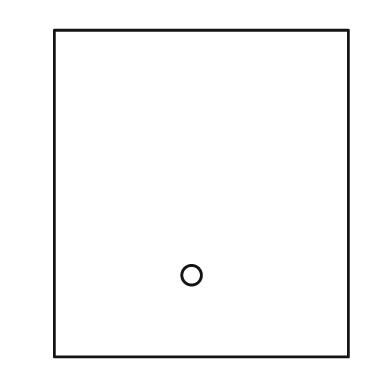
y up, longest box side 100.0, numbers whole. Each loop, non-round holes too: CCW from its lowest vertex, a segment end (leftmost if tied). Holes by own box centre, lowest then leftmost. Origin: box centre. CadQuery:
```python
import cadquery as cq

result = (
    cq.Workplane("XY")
    .moveTo(-45.0, -50.0)
    .lineTo(45.0, -50.0)
    .lineTo(45.0, 50.0)
    .lineTo(-45.0, 50.0)
    .close()
    .moveTo(-3.0, -25.0)
    .circle(3.0)
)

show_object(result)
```